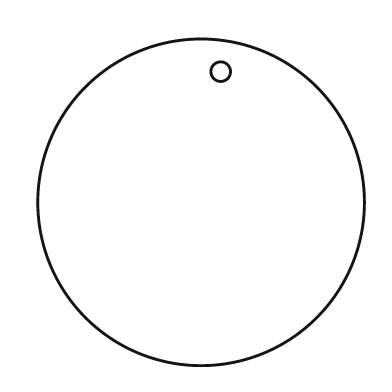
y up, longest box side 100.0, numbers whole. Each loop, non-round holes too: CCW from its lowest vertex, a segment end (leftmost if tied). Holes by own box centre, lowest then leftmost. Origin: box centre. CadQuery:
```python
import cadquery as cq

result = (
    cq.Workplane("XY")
    .moveTo(0.0, 0.0)
    .circle(50.0)
    .moveTo(6.0, 40.0)
    .circle(3.0)
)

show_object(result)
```